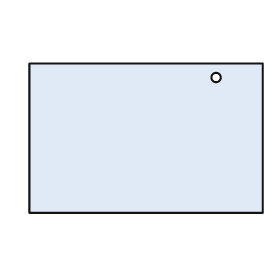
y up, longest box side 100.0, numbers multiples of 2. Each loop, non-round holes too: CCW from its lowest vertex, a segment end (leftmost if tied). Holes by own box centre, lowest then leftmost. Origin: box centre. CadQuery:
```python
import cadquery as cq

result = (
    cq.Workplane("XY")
    .moveTo(-50.0, -32.0)
    .lineTo(50.0, -32.0)
    .lineTo(50.0, 32.0)
    .lineTo(-50.0, 32.0)
    .close()
    .moveTo(30.0, 26.0)
    .circle(2.0)
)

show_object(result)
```